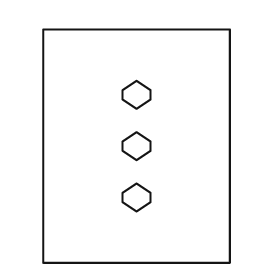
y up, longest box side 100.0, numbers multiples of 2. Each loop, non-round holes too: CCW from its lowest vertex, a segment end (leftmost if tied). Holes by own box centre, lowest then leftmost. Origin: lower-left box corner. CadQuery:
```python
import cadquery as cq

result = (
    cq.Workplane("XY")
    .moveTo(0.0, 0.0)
    .lineTo(80.0, 0.0)
    .lineTo(80.0, 100.0)
    .lineTo(0.0, 100.0)
    .close()
    .moveTo(40.0, 22.0)
    .lineTo(46.0, 26.0)
    .lineTo(46.0, 30.0)
    .lineTo(40.0, 34.0)
    .lineTo(34.0, 30.0)
    .lineTo(34.0, 26.0)
    .close()
    .moveTo(40.0, 44.0)
    .lineTo(46.0, 48.0)
    .lineTo(46.0, 52.0)
    .lineTo(40.0, 56.0)
    .lineTo(34.0, 52.0)
    .lineTo(34.0, 48.0)
    .close()
    .moveTo(40.0, 66.0)
    .lineTo(46.0, 70.0)
    .lineTo(46.0, 74.0)
    .lineTo(40.0, 78.0)
    .lineTo(34.0, 74.0)
    .lineTo(34.0, 70.0)
    .close()
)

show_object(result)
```